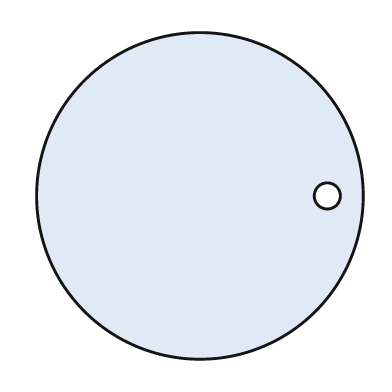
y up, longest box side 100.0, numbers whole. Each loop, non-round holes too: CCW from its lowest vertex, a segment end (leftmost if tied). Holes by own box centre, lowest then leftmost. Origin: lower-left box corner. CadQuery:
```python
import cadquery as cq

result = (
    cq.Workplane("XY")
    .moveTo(50.0, 50.0)
    .circle(50.0)
    .moveTo(89.0, 50.0)
    .circle(4.0)
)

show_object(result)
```